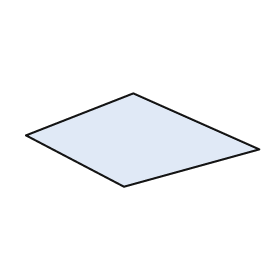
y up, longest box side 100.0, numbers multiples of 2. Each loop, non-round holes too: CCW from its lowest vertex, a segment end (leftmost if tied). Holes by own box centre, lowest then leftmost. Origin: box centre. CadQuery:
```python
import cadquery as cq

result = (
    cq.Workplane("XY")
    .moveTo(-8.0, -20.0)
    .lineTo(50.0, -4.0)
    .lineTo(-4.0, 20.0)
    .lineTo(-50.0, 2.0)
    .close()
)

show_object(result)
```